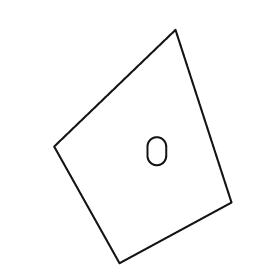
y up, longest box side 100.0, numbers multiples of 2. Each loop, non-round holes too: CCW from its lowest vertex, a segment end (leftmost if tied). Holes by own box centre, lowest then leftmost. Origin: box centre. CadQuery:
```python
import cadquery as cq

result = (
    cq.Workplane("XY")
    .moveTo(-10.0, -50.0)
    .lineTo(38.0, -24.0)
    .lineTo(14.0, 50.0)
    .lineTo(-38.0, 0.0)
    .close()
    .moveTo(2.0, -4.0)
    .threePointArc((6.0, -8.0), (10.0, -4.0))
    .lineTo(10.0, 0.0)
    .threePointArc((6.0, 4.0), (2.0, 0.0))
    .close()
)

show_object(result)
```